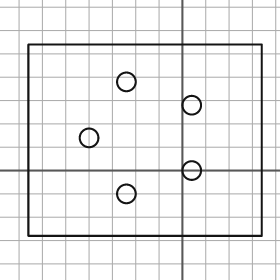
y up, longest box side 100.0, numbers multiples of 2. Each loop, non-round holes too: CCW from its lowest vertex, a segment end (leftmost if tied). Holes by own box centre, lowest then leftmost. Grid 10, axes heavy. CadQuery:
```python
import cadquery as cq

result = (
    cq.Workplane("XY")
    .moveTo(-66.0, -28.0)
    .lineTo(34.0, -28.0)
    .lineTo(34.0, 54.0)
    .lineTo(-66.0, 54.0)
    .close()
    .moveTo(-24.0, -10.0)
    .circle(4.0)
    .moveTo(4.0, 0.0)
    .circle(4.0)
    .moveTo(-40.0, 14.0)
    .circle(4.0)
    .moveTo(4.0, 28.0)
    .circle(4.0)
    .moveTo(-24.0, 38.0)
    .circle(4.0)
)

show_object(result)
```